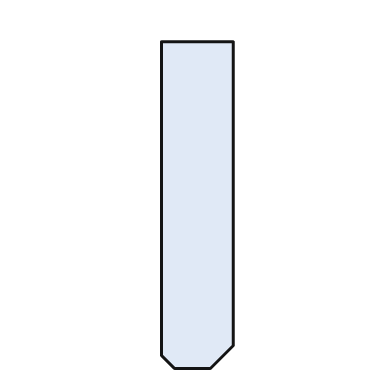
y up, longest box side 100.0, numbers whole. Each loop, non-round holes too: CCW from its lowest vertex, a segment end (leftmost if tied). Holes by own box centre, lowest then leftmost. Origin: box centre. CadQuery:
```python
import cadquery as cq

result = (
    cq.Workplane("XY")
    .moveTo(-7.0, -50.0)
    .lineTo(4.0, -50.0)
    .lineTo(11.0, -43.0)
    .lineTo(11.0, 50.0)
    .lineTo(-11.0, 50.0)
    .lineTo(-11.0, -46.0)
    .close()
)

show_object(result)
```